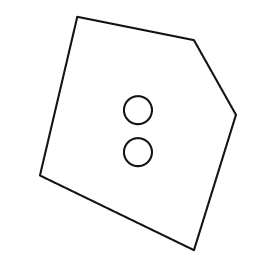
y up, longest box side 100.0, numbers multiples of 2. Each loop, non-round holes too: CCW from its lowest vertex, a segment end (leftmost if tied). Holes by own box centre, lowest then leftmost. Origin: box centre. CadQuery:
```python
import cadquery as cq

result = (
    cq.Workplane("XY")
    .moveTo(24.0, -50.0)
    .lineTo(42.0, 8.0)
    .lineTo(24.0, 40.0)
    .lineTo(-26.0, 50.0)
    .lineTo(-42.0, -18.0)
    .close()
    .moveTo(0.0, -8.0)
    .circle(6.0)
    .moveTo(0.0, 10.0)
    .circle(6.0)
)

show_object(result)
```